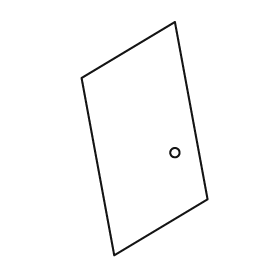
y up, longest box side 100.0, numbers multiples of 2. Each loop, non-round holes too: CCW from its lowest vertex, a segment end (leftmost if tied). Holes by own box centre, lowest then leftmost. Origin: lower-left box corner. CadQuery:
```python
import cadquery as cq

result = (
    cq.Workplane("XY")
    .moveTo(14.0, 0.0)
    .lineTo(54.0, 24.0)
    .lineTo(40.0, 100.0)
    .lineTo(0.0, 76.0)
    .close()
    .moveTo(40.0, 44.0)
    .circle(2.0)
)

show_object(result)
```